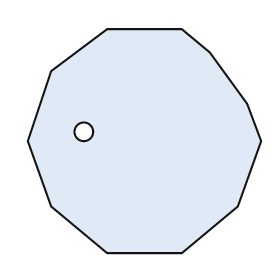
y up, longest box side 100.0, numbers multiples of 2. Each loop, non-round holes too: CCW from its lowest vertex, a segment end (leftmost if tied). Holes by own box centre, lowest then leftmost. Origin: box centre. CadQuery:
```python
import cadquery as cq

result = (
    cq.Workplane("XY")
    .moveTo(-16.0, -48.0)
    .lineTo(16.0, -48.0)
    .lineTo(40.0, -28.0)
    .lineTo(50.0, 0.0)
    .lineTo(44.0, 16.0)
    .lineTo(28.0, 38.0)
    .lineTo(16.0, 48.0)
    .lineTo(-16.0, 48.0)
    .lineTo(-40.0, 30.0)
    .lineTo(-50.0, 0.0)
    .lineTo(-40.0, -28.0)
    .close()
    .moveTo(-26.0, 4.0)
    .circle(4.0)
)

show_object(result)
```